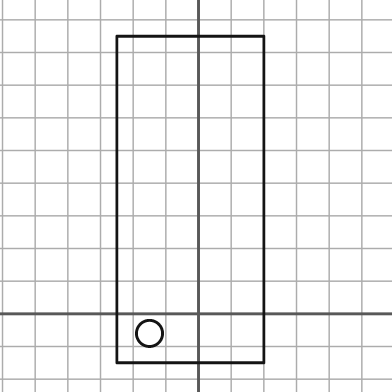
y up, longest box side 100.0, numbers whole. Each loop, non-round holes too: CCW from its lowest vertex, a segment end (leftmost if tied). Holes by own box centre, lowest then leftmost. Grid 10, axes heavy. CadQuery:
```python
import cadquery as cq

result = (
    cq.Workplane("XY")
    .moveTo(-25.0, -15.0)
    .lineTo(20.0, -15.0)
    .lineTo(20.0, 85.0)
    .lineTo(-25.0, 85.0)
    .close()
    .moveTo(-15.0, -6.0)
    .circle(4.0)
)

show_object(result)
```